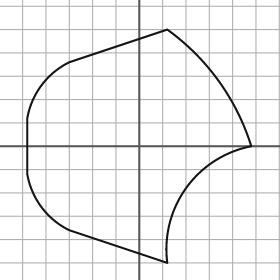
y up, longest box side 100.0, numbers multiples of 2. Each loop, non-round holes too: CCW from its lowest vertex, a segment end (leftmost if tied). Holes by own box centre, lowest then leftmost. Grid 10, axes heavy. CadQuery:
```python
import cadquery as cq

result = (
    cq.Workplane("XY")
    .moveTo(12.0, -50.0)
    .threePointArc((20.0, -18.0), (48.0, 0.0))
    .threePointArc((34.0, 28.0), (12.0, 50.0))
    .lineTo(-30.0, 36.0)
    .threePointArc((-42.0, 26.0), (-48.0, 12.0))
    .lineTo(-48.0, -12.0)
    .threePointArc((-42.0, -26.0), (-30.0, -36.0))
    .close()
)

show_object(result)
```